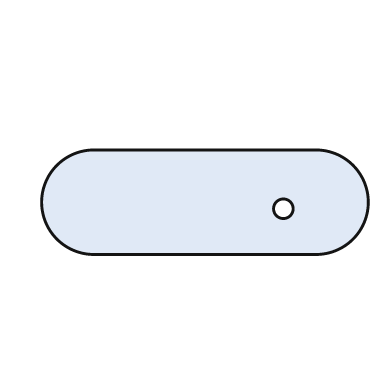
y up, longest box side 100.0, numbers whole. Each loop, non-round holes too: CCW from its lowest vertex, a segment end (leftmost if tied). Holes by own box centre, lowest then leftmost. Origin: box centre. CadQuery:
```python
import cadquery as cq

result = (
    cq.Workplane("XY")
    .moveTo(-34.0, -16.0)
    .lineTo(34.0, -16.0)
    .threePointArc((50.0, 0.0), (34.0, 16.0))
    .lineTo(-34.0, 16.0)
    .threePointArc((-50.0, 0.0), (-34.0, -16.0))
    .close()
    .moveTo(24.0, -2.0)
    .circle(3.0)
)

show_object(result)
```